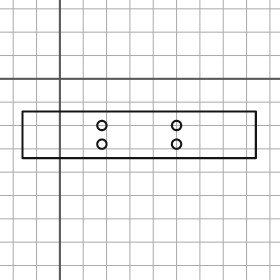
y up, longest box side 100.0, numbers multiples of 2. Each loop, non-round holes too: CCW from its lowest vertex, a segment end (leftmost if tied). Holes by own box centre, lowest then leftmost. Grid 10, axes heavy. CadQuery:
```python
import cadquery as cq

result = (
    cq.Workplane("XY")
    .moveTo(-16.0, -34.0)
    .lineTo(84.0, -34.0)
    .lineTo(84.0, -14.0)
    .lineTo(-16.0, -14.0)
    .close()
    .moveTo(18.0, -28.0)
    .circle(2.0)
    .moveTo(50.0, -28.0)
    .circle(2.0)
    .moveTo(18.0, -20.0)
    .circle(2.0)
    .moveTo(50.0, -20.0)
    .circle(2.0)
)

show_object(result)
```